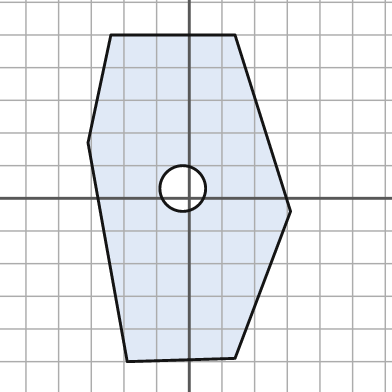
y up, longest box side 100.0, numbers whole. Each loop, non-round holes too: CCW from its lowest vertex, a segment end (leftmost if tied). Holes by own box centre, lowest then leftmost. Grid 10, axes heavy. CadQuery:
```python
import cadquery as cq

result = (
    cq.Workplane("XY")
    .moveTo(-19.0, -50.0)
    .lineTo(14.0, -49.0)
    .lineTo(31.0, -4.0)
    .lineTo(14.0, 50.0)
    .lineTo(-24.0, 50.0)
    .lineTo(-31.0, 17.0)
    .close()
    .moveTo(-2.0, 3.0)
    .circle(7.0)
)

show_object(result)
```